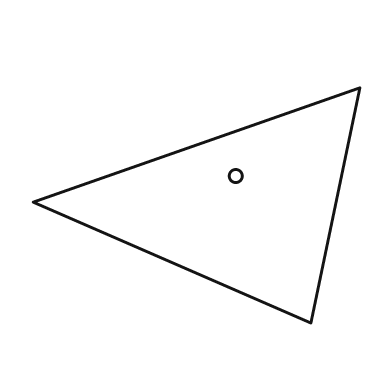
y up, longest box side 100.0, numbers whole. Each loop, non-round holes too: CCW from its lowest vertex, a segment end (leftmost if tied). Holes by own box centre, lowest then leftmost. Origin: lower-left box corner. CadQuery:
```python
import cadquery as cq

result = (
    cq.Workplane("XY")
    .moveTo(85.0, 0.0)
    .lineTo(100.0, 72.0)
    .lineTo(0.0, 37.0)
    .close()
    .moveTo(62.0, 45.0)
    .circle(2.0)
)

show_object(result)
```